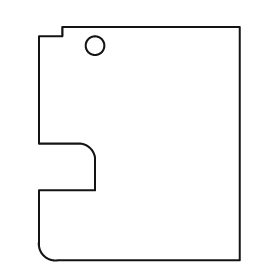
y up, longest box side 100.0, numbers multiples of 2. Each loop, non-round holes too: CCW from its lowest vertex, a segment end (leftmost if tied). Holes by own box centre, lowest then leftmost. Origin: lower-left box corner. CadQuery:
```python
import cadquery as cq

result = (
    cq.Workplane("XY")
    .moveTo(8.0, 0.0)
    .lineTo(86.0, 0.0)
    .lineTo(86.0, 100.0)
    .lineTo(10.0, 100.0)
    .lineTo(10.0, 96.0)
    .lineTo(0.0, 96.0)
    .lineTo(0.0, 50.0)
    .lineTo(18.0, 50.0)
    .threePointArc((22.0, 48.0), (24.0, 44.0))
    .lineTo(24.0, 30.0)
    .lineTo(0.0, 30.0)
    .lineTo(0.0, 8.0)
    .threePointArc((2.0, 2.0), (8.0, 0.0))
    .close()
    .moveTo(24.0, 92.0)
    .circle(4.0)
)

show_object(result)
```